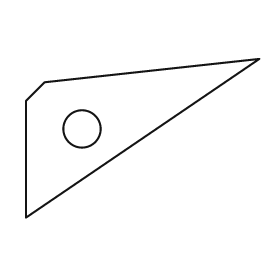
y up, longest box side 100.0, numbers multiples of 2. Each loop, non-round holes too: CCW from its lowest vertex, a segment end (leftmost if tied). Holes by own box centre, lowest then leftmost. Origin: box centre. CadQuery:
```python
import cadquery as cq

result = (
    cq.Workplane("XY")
    .moveTo(-50.0, -34.0)
    .lineTo(50.0, 34.0)
    .lineTo(-42.0, 24.0)
    .lineTo(-50.0, 16.0)
    .close()
    .moveTo(-26.0, 4.0)
    .circle(8.0)
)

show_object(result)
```